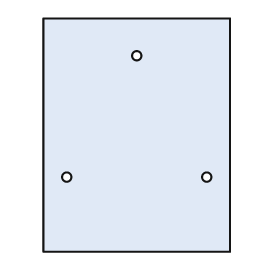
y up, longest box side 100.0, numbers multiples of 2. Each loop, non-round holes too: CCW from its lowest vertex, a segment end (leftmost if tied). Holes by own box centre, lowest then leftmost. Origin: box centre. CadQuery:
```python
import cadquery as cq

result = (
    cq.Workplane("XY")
    .moveTo(-40.0, -50.0)
    .lineTo(40.0, -50.0)
    .lineTo(40.0, 50.0)
    .lineTo(-40.0, 50.0)
    .close()
    .moveTo(-30.0, -18.0)
    .circle(2.0)
    .moveTo(30.0, -18.0)
    .circle(2.0)
    .moveTo(0.0, 34.0)
    .circle(2.0)
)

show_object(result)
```